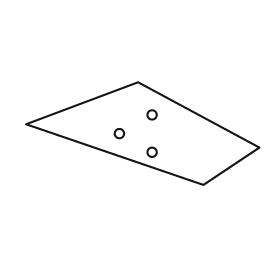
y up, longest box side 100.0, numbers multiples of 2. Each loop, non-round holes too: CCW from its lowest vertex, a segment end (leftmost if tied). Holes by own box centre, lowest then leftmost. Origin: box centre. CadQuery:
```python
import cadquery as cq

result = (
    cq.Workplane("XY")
    .moveTo(26.0, -22.0)
    .lineTo(50.0, -6.0)
    .lineTo(-2.0, 22.0)
    .lineTo(-50.0, 4.0)
    .close()
    .moveTo(4.0, -8.0)
    .circle(2.0)
    .moveTo(-10.0, 0.0)
    .circle(2.0)
    .moveTo(4.0, 8.0)
    .circle(2.0)
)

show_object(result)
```